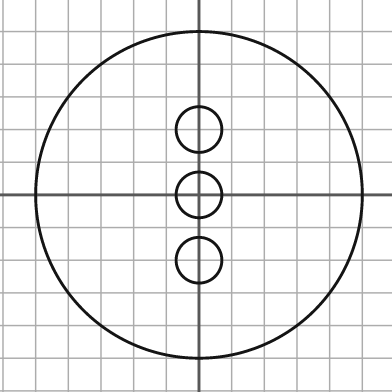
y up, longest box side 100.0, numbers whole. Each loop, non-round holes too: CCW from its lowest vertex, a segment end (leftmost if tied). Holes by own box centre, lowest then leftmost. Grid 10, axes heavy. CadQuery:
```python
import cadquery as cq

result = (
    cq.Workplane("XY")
    .moveTo(0.0, 0.0)
    .circle(50.0)
    .moveTo(0.0, -20.0)
    .circle(7.0)
    .moveTo(0.0, 0.0)
    .circle(7.0)
    .moveTo(0.0, 20.0)
    .circle(7.0)
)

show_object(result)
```